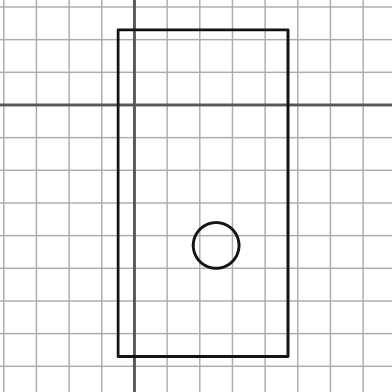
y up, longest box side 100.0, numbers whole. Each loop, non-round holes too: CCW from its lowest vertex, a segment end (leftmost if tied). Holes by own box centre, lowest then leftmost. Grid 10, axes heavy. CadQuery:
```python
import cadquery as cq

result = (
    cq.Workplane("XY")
    .moveTo(-5.0, -77.0)
    .lineTo(47.0, -77.0)
    .lineTo(47.0, 23.0)
    .lineTo(-5.0, 23.0)
    .close()
    .moveTo(25.0, -43.0)
    .circle(7.0)
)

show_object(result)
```